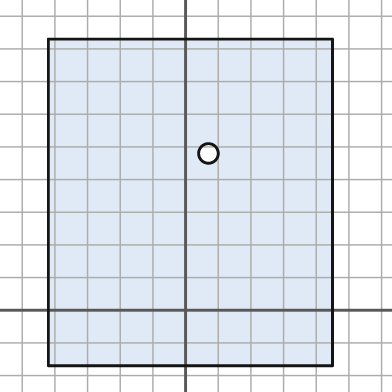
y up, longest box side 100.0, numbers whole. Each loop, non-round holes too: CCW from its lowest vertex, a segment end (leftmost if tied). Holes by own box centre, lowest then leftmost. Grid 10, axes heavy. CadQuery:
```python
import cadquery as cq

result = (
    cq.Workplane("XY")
    .moveTo(-42.0, -17.0)
    .lineTo(45.0, -17.0)
    .lineTo(45.0, 83.0)
    .lineTo(-42.0, 83.0)
    .close()
    .moveTo(7.0, 48.0)
    .circle(3.0)
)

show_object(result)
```